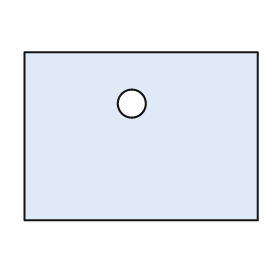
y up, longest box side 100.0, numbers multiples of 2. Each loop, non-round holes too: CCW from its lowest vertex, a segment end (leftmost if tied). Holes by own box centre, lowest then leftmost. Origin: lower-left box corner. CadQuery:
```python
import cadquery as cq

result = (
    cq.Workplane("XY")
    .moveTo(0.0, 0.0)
    .lineTo(100.0, 0.0)
    .lineTo(100.0, 72.0)
    .lineTo(0.0, 72.0)
    .close()
    .moveTo(46.0, 50.0)
    .circle(6.0)
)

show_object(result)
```